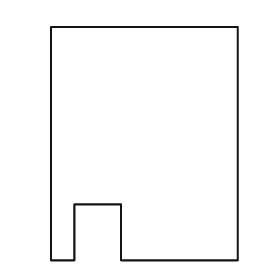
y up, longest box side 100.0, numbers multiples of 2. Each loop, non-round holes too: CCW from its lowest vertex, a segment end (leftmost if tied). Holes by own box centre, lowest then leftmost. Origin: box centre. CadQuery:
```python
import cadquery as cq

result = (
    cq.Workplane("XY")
    .moveTo(-40.0, -50.0)
    .lineTo(-30.0, -50.0)
    .lineTo(-30.0, -26.0)
    .lineTo(-10.0, -26.0)
    .lineTo(-10.0, -50.0)
    .lineTo(40.0, -50.0)
    .lineTo(40.0, 50.0)
    .lineTo(-40.0, 50.0)
    .close()
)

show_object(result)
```